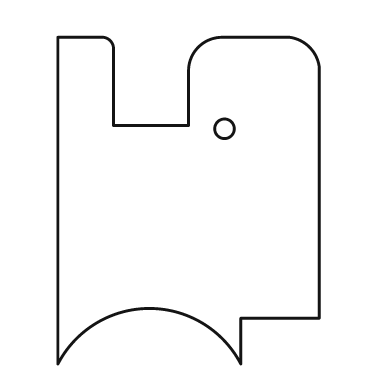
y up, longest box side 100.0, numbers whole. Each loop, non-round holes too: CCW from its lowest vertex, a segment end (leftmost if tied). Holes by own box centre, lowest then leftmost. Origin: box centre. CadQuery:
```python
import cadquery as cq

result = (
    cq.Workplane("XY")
    .moveTo(-40.0, -50.0)
    .threePointArc((-12.0, -33.0), (16.0, -50.0))
    .lineTo(16.0, -36.0)
    .lineTo(40.0, -36.0)
    .lineTo(40.0, 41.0)
    .threePointArc((37.0, 47.0), (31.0, 50.0))
    .lineTo(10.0, 50.0)
    .threePointArc((3.0, 47.0), (0.0, 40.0))
    .lineTo(0.0, 23.0)
    .lineTo(-23.0, 23.0)
    .lineTo(-23.0, 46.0)
    .threePointArc((-24.0, 49.0), (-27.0, 50.0))
    .lineTo(-40.0, 50.0)
    .close()
    .moveTo(11.0, 22.0)
    .circle(3.0)
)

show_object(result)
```